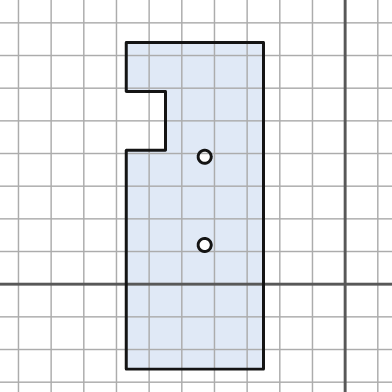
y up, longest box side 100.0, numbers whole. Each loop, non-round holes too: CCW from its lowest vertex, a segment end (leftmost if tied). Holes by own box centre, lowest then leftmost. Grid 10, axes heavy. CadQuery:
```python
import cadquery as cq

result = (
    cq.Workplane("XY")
    .moveTo(-67.0, -26.0)
    .lineTo(-25.0, -26.0)
    .lineTo(-25.0, 74.0)
    .lineTo(-67.0, 74.0)
    .lineTo(-67.0, 59.0)
    .lineTo(-55.0, 59.0)
    .lineTo(-55.0, 41.0)
    .lineTo(-67.0, 41.0)
    .close()
    .moveTo(-43.0, 12.0)
    .circle(2.0)
    .moveTo(-43.0, 39.0)
    .circle(2.0)
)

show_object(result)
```